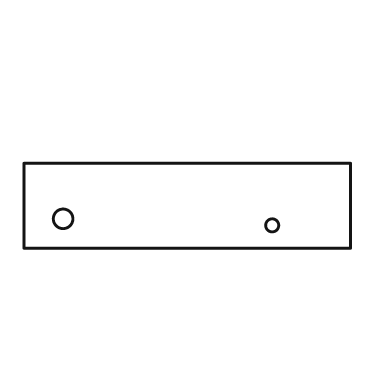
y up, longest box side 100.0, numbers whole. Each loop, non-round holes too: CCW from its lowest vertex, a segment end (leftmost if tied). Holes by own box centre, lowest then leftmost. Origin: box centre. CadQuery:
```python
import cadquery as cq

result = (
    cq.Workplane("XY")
    .moveTo(-50.0, -13.0)
    .lineTo(50.0, -13.0)
    .lineTo(50.0, 13.0)
    .lineTo(-50.0, 13.0)
    .close()
    .moveTo(26.0, -6.0)
    .circle(2.0)
    .moveTo(-38.0, -4.0)
    .circle(3.0)
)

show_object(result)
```